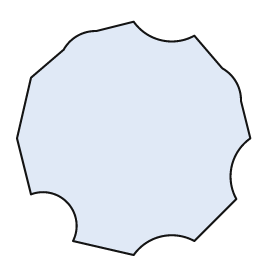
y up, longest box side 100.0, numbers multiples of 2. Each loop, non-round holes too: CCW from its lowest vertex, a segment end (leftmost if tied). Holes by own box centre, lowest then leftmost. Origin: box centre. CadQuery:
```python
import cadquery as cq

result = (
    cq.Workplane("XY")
    .moveTo(0.0, -50.0)
    .threePointArc((12.0, -42.0), (26.0, -44.0))
    .lineTo(44.0, -26.0)
    .threePointArc((42.0, -12.0), (50.0, 0.0))
    .lineTo(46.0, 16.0)
    .threePointArc((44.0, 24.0), (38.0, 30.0))
    .lineTo(26.0, 44.0)
    .threePointArc((12.0, 42.0), (0.0, 50.0))
    .lineTo(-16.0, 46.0)
    .threePointArc((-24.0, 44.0), (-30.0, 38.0))
    .lineTo(-44.0, 26.0)
    .lineTo(-50.0, 0.0)
    .lineTo(-44.0, -24.0)
    .threePointArc((-28.0, -28.0), (-26.0, -44.0))
    .close()
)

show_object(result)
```